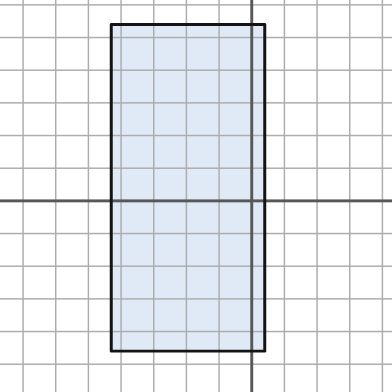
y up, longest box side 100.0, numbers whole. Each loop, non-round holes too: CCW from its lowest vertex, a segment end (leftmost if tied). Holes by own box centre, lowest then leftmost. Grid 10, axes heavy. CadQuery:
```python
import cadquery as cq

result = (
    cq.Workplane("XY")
    .moveTo(-43.0, -46.0)
    .lineTo(4.0, -46.0)
    .lineTo(4.0, 54.0)
    .lineTo(-43.0, 54.0)
    .close()
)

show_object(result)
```